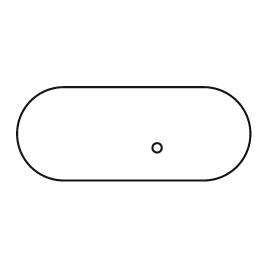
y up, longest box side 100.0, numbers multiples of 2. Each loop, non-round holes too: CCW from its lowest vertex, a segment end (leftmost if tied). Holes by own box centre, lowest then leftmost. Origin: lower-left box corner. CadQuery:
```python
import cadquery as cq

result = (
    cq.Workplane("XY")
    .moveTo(20.0, 0.0)
    .lineTo(80.0, 0.0)
    .threePointArc((100.0, 20.0), (80.0, 40.0))
    .lineTo(20.0, 40.0)
    .threePointArc((0.0, 20.0), (20.0, 0.0))
    .close()
    .moveTo(60.0, 14.0)
    .circle(2.0)
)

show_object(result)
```